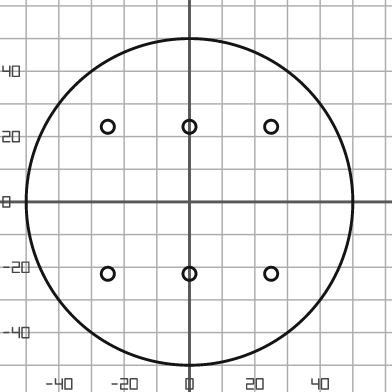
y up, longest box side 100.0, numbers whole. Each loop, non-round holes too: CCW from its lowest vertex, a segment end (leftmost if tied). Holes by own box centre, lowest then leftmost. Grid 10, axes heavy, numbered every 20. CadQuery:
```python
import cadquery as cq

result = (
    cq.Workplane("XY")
    .moveTo(0.0, 0.0)
    .circle(50.0)
    .moveTo(-25.0, -22.0)
    .circle(2.0)
    .moveTo(0.0, -22.0)
    .circle(2.0)
    .moveTo(25.0, -22.0)
    .circle(2.0)
    .moveTo(-25.0, 23.0)
    .circle(2.0)
    .moveTo(0.0, 23.0)
    .circle(2.0)
    .moveTo(25.0, 23.0)
    .circle(2.0)
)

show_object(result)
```